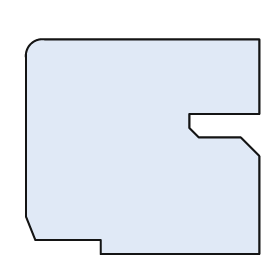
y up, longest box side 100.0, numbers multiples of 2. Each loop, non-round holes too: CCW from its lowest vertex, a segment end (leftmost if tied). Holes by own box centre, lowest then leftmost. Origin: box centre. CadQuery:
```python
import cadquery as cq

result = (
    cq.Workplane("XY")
    .moveTo(-18.0, -46.0)
    .lineTo(50.0, -46.0)
    .lineTo(50.0, -4.0)
    .lineTo(42.0, 4.0)
    .lineTo(24.0, 4.0)
    .lineTo(20.0, 8.0)
    .lineTo(20.0, 14.0)
    .lineTo(50.0, 14.0)
    .lineTo(50.0, 46.0)
    .lineTo(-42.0, 46.0)
    .threePointArc((-48.0, 44.0), (-50.0, 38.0))
    .lineTo(-50.0, -30.0)
    .lineTo(-46.0, -40.0)
    .lineTo(-18.0, -40.0)
    .close()
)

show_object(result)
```